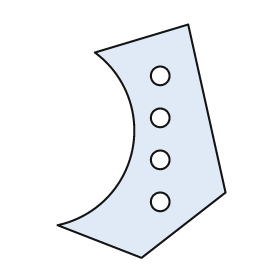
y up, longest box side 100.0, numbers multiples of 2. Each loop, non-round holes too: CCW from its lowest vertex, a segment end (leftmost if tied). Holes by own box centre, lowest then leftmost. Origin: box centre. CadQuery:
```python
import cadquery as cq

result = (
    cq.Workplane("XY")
    .moveTo(0.0, -50.0)
    .lineTo(36.0, -22.0)
    .lineTo(20.0, 50.0)
    .lineTo(-20.0, 38.0)
    .threePointArc((-4.0, -4.0), (-36.0, -36.0))
    .close()
    .moveTo(8.0, -26.0)
    .circle(4.0)
    .moveTo(8.0, -8.0)
    .circle(4.0)
    .moveTo(8.0, 10.0)
    .circle(4.0)
    .moveTo(8.0, 28.0)
    .circle(4.0)
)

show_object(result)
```